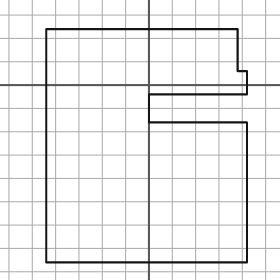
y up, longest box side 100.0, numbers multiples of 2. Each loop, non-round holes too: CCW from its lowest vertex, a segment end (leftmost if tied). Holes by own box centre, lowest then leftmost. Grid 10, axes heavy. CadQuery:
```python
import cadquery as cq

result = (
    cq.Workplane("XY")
    .moveTo(-44.0, -76.0)
    .lineTo(42.0, -76.0)
    .lineTo(42.0, -16.0)
    .lineTo(0.0, -16.0)
    .lineTo(0.0, -4.0)
    .lineTo(42.0, -4.0)
    .lineTo(42.0, 6.0)
    .lineTo(38.0, 6.0)
    .lineTo(38.0, 24.0)
    .lineTo(-44.0, 24.0)
    .close()
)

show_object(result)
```